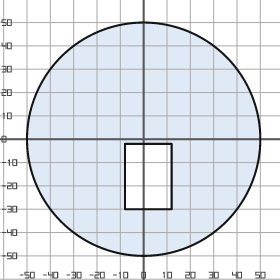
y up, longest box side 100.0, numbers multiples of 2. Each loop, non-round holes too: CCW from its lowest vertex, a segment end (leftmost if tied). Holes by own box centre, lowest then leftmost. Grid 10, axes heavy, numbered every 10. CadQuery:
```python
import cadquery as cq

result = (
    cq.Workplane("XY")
    .moveTo(0.0, 0.0)
    .circle(50.0)
    .moveTo(-8.0, -30.0)
    .lineTo(12.0, -30.0)
    .lineTo(12.0, -2.0)
    .lineTo(-8.0, -2.0)
    .close()
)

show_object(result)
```